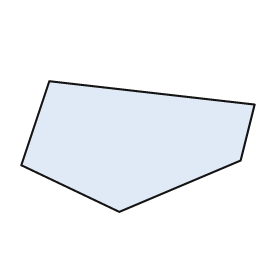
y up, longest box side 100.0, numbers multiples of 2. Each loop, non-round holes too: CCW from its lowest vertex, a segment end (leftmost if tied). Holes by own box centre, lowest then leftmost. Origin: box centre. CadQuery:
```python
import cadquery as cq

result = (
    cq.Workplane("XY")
    .moveTo(-8.0, -28.0)
    .lineTo(44.0, -6.0)
    .lineTo(50.0, 18.0)
    .lineTo(-38.0, 28.0)
    .lineTo(-50.0, -8.0)
    .close()
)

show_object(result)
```